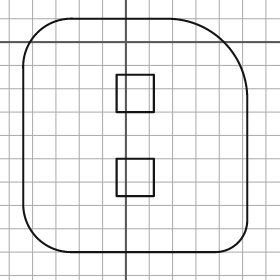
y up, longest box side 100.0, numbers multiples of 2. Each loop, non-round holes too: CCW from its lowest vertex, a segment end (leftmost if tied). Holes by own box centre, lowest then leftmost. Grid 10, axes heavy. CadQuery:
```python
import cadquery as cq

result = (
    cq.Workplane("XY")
    .moveTo(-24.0, -90.0)
    .lineTo(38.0, -90.0)
    .threePointArc((48.0, -86.0), (52.0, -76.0))
    .lineTo(52.0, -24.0)
    .threePointArc((42.0, 0.0), (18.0, 10.0))
    .lineTo(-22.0, 10.0)
    .threePointArc((-38.0, 4.0), (-44.0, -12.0))
    .lineTo(-44.0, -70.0)
    .threePointArc((-38.0, -84.0), (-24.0, -90.0))
    .close()
    .moveTo(-4.0, -66.0)
    .lineTo(12.0, -66.0)
    .lineTo(12.0, -50.0)
    .lineTo(-4.0, -50.0)
    .close()
    .moveTo(-4.0, -30.0)
    .lineTo(12.0, -30.0)
    .lineTo(12.0, -14.0)
    .lineTo(-4.0, -14.0)
    .close()
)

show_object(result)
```